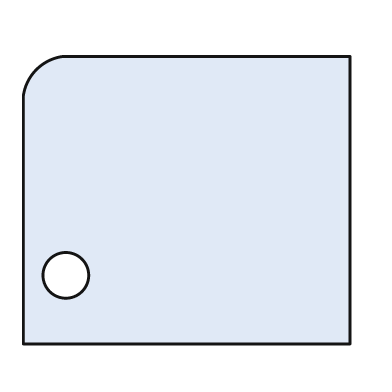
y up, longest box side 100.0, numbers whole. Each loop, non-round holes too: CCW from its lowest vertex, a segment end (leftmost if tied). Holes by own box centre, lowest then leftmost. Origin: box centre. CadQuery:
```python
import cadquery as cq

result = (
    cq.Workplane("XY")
    .moveTo(-50.0, -44.0)
    .lineTo(50.0, -44.0)
    .lineTo(50.0, 44.0)
    .lineTo(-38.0, 44.0)
    .threePointArc((-46.0, 40.0), (-50.0, 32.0))
    .close()
    .moveTo(-37.0, -23.0)
    .circle(7.0)
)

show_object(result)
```